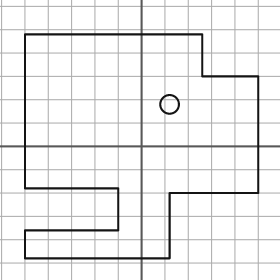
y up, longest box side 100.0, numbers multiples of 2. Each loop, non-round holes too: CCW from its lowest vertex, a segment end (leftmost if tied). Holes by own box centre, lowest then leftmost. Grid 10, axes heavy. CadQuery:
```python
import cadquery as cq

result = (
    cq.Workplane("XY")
    .moveTo(-50.0, -48.0)
    .lineTo(12.0, -48.0)
    .lineTo(12.0, -20.0)
    .lineTo(50.0, -20.0)
    .lineTo(50.0, 30.0)
    .lineTo(26.0, 30.0)
    .lineTo(26.0, 48.0)
    .lineTo(-50.0, 48.0)
    .lineTo(-50.0, -18.0)
    .lineTo(-10.0, -18.0)
    .lineTo(-10.0, -36.0)
    .lineTo(-50.0, -36.0)
    .close()
    .moveTo(12.0, 18.0)
    .circle(4.0)
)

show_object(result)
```